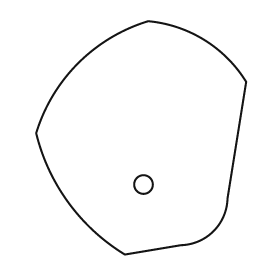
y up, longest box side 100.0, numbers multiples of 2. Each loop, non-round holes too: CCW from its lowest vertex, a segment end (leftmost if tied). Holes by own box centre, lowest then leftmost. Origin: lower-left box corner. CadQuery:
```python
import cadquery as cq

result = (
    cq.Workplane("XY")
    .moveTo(38.0, 0.0)
    .lineTo(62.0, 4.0)
    .threePointArc((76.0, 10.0), (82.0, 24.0))
    .lineTo(90.0, 74.0)
    .threePointArc((72.0, 92.0), (48.0, 100.0))
    .threePointArc((18.0, 82.0), (0.0, 52.0))
    .threePointArc((14.0, 22.0), (38.0, 0.0))
    .close()
    .moveTo(46.0, 30.0)
    .circle(4.0)
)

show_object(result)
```